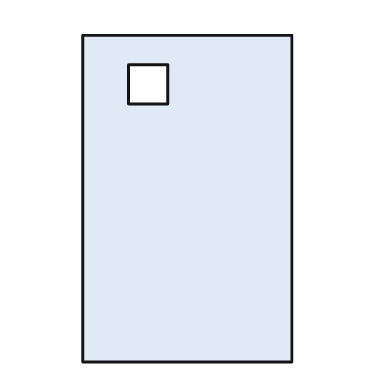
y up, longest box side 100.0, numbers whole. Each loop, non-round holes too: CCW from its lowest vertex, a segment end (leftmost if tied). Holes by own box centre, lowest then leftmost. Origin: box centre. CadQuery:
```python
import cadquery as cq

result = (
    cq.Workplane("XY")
    .moveTo(-32.0, -50.0)
    .lineTo(32.0, -50.0)
    .lineTo(32.0, 50.0)
    .lineTo(-32.0, 50.0)
    .close()
    .moveTo(-18.0, 29.0)
    .lineTo(-6.0, 29.0)
    .lineTo(-6.0, 41.0)
    .lineTo(-18.0, 41.0)
    .close()
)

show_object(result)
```